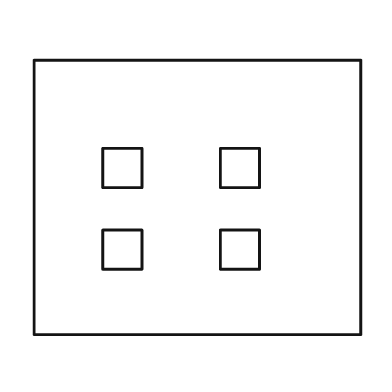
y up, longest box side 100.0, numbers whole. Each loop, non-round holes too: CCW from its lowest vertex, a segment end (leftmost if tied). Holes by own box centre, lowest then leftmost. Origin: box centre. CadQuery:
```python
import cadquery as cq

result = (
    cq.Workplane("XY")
    .moveTo(-50.0, -42.0)
    .lineTo(50.0, -42.0)
    .lineTo(50.0, 42.0)
    .lineTo(-50.0, 42.0)
    .close()
    .moveTo(-29.0, -22.0)
    .lineTo(-17.0, -22.0)
    .lineTo(-17.0, -10.0)
    .lineTo(-29.0, -10.0)
    .close()
    .moveTo(7.0, -22.0)
    .lineTo(19.0, -22.0)
    .lineTo(19.0, -10.0)
    .lineTo(7.0, -10.0)
    .close()
    .moveTo(-29.0, 3.0)
    .lineTo(-17.0, 3.0)
    .lineTo(-17.0, 15.0)
    .lineTo(-29.0, 15.0)
    .close()
    .moveTo(7.0, 3.0)
    .lineTo(19.0, 3.0)
    .lineTo(19.0, 15.0)
    .lineTo(7.0, 15.0)
    .close()
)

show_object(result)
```